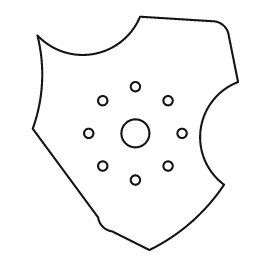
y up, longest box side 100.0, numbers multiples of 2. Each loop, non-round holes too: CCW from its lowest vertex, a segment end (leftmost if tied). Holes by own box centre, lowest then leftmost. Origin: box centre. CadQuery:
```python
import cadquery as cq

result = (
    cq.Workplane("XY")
    .moveTo(6.0, -50.0)
    .threePointArc((24.0, -38.0), (38.0, -22.0))
    .threePointArc((28.0, 2.0), (44.0, 22.0))
    .lineTo(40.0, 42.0)
    .threePointArc((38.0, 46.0), (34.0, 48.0))
    .lineTo(2.0, 50.0)
    .threePointArc((-18.0, 34.0), (-42.0, 42.0))
    .threePointArc((-40.0, 22.0), (-44.0, 2.0))
    .lineTo(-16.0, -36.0)
    .threePointArc((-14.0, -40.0), (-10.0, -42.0))
    .close()
    .moveTo(0.0, -20.0)
    .circle(2.0)
    .moveTo(-14.0, -14.0)
    .circle(2.0)
    .moveTo(14.0, -14.0)
    .circle(2.0)
    .moveTo(-20.0, 0.0)
    .circle(2.0)
    .moveTo(0.0, 0.0)
    .circle(6.0)
    .moveTo(20.0, 0.0)
    .circle(2.0)
    .moveTo(-14.0, 14.0)
    .circle(2.0)
    .moveTo(14.0, 14.0)
    .circle(2.0)
    .moveTo(0.0, 20.0)
    .circle(2.0)
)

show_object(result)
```